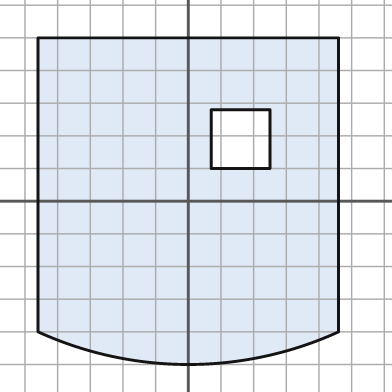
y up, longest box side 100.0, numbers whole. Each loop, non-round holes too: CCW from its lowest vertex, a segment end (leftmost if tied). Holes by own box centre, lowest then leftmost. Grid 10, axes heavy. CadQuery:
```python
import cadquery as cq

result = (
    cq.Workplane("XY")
    .moveTo(-46.0, -40.0)
    .threePointArc((0.0, -50.0), (46.0, -40.0))
    .lineTo(46.0, 50.0)
    .lineTo(-46.0, 50.0)
    .close()
    .moveTo(7.0, 10.0)
    .lineTo(25.0, 10.0)
    .lineTo(25.0, 28.0)
    .lineTo(7.0, 28.0)
    .close()
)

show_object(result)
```